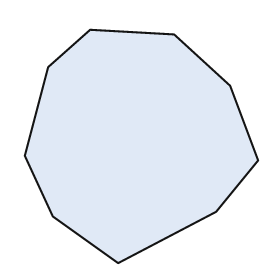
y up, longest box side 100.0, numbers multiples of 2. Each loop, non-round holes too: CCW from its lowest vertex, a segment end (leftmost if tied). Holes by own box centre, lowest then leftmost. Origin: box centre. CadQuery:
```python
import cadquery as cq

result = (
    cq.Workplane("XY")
    .moveTo(-10.0, -50.0)
    .lineTo(32.0, -28.0)
    .lineTo(50.0, -6.0)
    .lineTo(38.0, 26.0)
    .lineTo(14.0, 48.0)
    .lineTo(-22.0, 50.0)
    .lineTo(-40.0, 34.0)
    .lineTo(-50.0, -4.0)
    .lineTo(-38.0, -30.0)
    .close()
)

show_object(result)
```